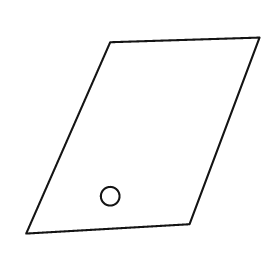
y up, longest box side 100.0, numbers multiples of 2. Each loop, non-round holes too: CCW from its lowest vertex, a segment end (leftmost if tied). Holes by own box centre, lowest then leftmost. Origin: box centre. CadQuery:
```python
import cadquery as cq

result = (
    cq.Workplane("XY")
    .moveTo(-50.0, -42.0)
    .lineTo(20.0, -38.0)
    .lineTo(50.0, 42.0)
    .lineTo(-14.0, 40.0)
    .close()
    .moveTo(-14.0, -26.0)
    .circle(4.0)
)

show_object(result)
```